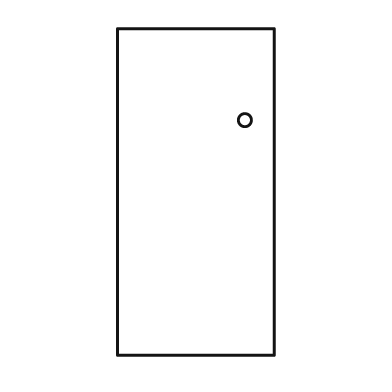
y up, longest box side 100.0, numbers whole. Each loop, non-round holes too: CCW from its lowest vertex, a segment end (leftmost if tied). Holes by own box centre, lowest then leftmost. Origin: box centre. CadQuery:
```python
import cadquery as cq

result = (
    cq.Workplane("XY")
    .moveTo(-24.0, -50.0)
    .lineTo(24.0, -50.0)
    .lineTo(24.0, 50.0)
    .lineTo(-24.0, 50.0)
    .close()
    .moveTo(15.0, 22.0)
    .circle(2.0)
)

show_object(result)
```